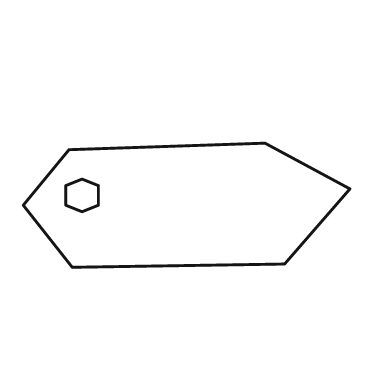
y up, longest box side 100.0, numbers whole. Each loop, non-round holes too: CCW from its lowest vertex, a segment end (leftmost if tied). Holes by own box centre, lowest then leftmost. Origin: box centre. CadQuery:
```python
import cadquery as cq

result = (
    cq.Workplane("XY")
    .moveTo(-35.0, -19.0)
    .lineTo(30.0, -18.0)
    .lineTo(50.0, 5.0)
    .lineTo(24.0, 19.0)
    .lineTo(-36.0, 17.0)
    .lineTo(-50.0, 0.0)
    .close()
    .moveTo(-32.0, -2.0)
    .lineTo(-27.0, 0.0)
    .lineTo(-27.0, 6.0)
    .lineTo(-32.0, 8.0)
    .lineTo(-37.0, 6.0)
    .lineTo(-37.0, 0.0)
    .close()
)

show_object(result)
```